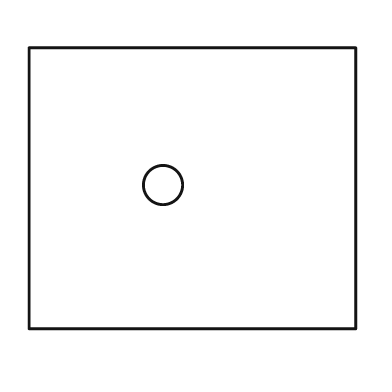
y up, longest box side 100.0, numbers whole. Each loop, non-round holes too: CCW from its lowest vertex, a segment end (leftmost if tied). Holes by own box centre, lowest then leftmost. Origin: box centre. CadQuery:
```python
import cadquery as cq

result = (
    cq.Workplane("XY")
    .moveTo(-50.0, -43.0)
    .lineTo(50.0, -43.0)
    .lineTo(50.0, 43.0)
    .lineTo(-50.0, 43.0)
    .close()
    .moveTo(-9.0, 1.0)
    .circle(6.0)
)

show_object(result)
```